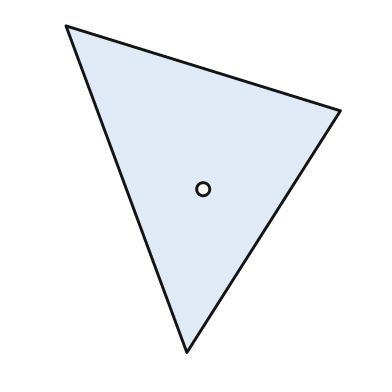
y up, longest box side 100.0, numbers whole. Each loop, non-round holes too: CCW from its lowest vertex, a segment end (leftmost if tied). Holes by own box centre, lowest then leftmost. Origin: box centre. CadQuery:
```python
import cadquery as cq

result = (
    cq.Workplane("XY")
    .moveTo(-5.0, -50.0)
    .lineTo(42.0, 24.0)
    .lineTo(-42.0, 50.0)
    .close()
    .moveTo(0.0, 0.0)
    .circle(2.0)
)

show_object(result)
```